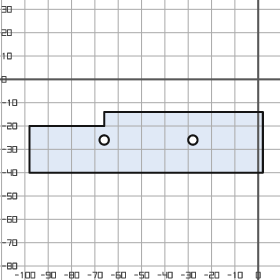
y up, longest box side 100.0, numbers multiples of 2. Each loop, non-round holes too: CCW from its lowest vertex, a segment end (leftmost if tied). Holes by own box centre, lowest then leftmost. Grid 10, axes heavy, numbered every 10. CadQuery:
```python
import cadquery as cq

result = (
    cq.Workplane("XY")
    .moveTo(-98.0, -40.0)
    .lineTo(2.0, -40.0)
    .lineTo(2.0, -14.0)
    .lineTo(-66.0, -14.0)
    .lineTo(-66.0, -20.0)
    .lineTo(-98.0, -20.0)
    .close()
    .moveTo(-66.0, -26.0)
    .circle(2.0)
    .moveTo(-28.0, -26.0)
    .circle(2.0)
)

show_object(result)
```